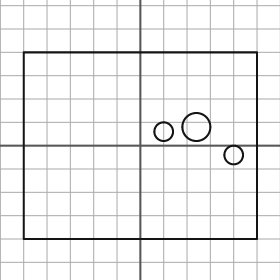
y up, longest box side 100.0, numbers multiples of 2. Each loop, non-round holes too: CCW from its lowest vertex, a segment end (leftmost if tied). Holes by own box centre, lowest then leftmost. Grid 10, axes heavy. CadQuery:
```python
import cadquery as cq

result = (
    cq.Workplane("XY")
    .moveTo(-50.0, -40.0)
    .lineTo(50.0, -40.0)
    .lineTo(50.0, 40.0)
    .lineTo(-50.0, 40.0)
    .close()
    .moveTo(40.0, -4.0)
    .circle(4.0)
    .moveTo(10.0, 6.0)
    .circle(4.0)
    .moveTo(24.0, 8.0)
    .circle(6.0)
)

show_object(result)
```